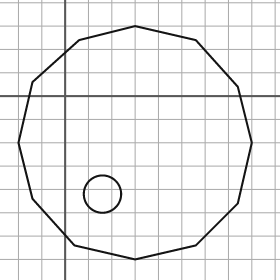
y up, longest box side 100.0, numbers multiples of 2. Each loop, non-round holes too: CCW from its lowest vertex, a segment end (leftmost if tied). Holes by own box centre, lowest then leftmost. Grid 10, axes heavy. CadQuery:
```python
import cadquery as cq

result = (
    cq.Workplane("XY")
    .moveTo(30.0, -70.0)
    .lineTo(56.0, -64.0)
    .lineTo(74.0, -46.0)
    .lineTo(80.0, -20.0)
    .lineTo(74.0, 4.0)
    .lineTo(56.0, 24.0)
    .lineTo(30.0, 30.0)
    .lineTo(6.0, 24.0)
    .lineTo(-14.0, 6.0)
    .lineTo(-20.0, -20.0)
    .lineTo(-14.0, -44.0)
    .lineTo(4.0, -64.0)
    .close()
    .moveTo(16.0, -42.0)
    .circle(8.0)
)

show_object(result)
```